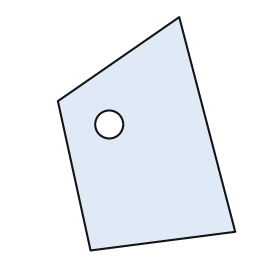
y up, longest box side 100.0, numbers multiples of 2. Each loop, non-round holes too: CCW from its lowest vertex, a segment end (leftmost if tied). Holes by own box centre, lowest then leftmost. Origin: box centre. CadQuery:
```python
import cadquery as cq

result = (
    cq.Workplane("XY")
    .moveTo(-24.0, -50.0)
    .lineTo(38.0, -42.0)
    .lineTo(14.0, 50.0)
    .lineTo(-38.0, 14.0)
    .close()
    .moveTo(-16.0, 4.0)
    .circle(6.0)
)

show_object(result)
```